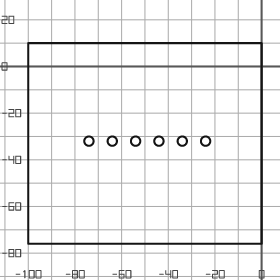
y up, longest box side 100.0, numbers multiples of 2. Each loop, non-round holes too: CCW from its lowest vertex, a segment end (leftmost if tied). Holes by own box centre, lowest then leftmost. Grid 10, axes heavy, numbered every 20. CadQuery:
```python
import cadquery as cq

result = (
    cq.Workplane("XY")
    .moveTo(-100.0, -76.0)
    .lineTo(0.0, -76.0)
    .lineTo(0.0, 10.0)
    .lineTo(-100.0, 10.0)
    .close()
    .moveTo(-74.0, -32.0)
    .circle(2.0)
    .moveTo(-64.0, -32.0)
    .circle(2.0)
    .moveTo(-54.0, -32.0)
    .circle(2.0)
    .moveTo(-44.0, -32.0)
    .circle(2.0)
    .moveTo(-34.0, -32.0)
    .circle(2.0)
    .moveTo(-24.0, -32.0)
    .circle(2.0)
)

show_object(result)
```